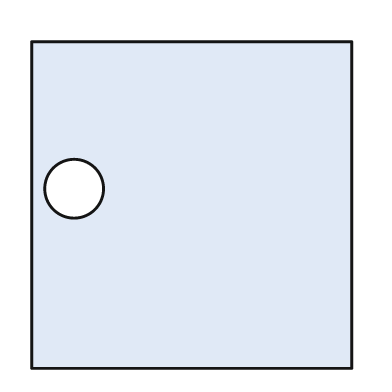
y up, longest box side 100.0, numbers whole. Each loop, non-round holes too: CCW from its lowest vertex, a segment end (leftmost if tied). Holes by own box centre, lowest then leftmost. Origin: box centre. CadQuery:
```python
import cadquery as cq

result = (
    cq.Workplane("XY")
    .moveTo(-49.0, -50.0)
    .lineTo(49.0, -50.0)
    .lineTo(49.0, 50.0)
    .lineTo(-49.0, 50.0)
    .close()
    .moveTo(-36.0, 5.0)
    .circle(9.0)
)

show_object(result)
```